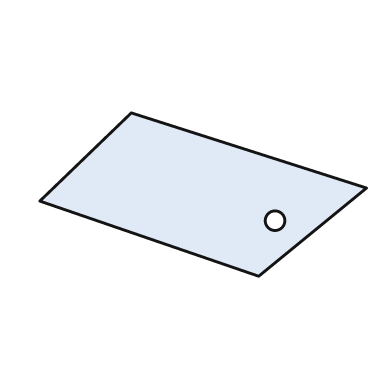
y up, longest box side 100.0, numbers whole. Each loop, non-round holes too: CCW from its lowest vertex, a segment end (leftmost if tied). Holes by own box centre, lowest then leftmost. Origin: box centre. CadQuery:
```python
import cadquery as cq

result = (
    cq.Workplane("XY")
    .moveTo(17.0, -25.0)
    .lineTo(50.0, 2.0)
    .lineTo(-22.0, 25.0)
    .lineTo(-50.0, -2.0)
    .close()
    .moveTo(22.0, -8.0)
    .circle(3.0)
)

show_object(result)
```